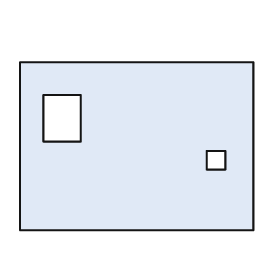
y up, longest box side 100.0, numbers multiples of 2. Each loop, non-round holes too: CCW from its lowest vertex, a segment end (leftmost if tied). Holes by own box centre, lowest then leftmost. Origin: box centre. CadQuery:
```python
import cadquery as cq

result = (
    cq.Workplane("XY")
    .moveTo(-50.0, -36.0)
    .lineTo(50.0, -36.0)
    .lineTo(50.0, 36.0)
    .lineTo(-50.0, 36.0)
    .close()
    .moveTo(30.0, -10.0)
    .lineTo(38.0, -10.0)
    .lineTo(38.0, -2.0)
    .lineTo(30.0, -2.0)
    .close()
    .moveTo(-40.0, 2.0)
    .lineTo(-24.0, 2.0)
    .lineTo(-24.0, 22.0)
    .lineTo(-40.0, 22.0)
    .close()
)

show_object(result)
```